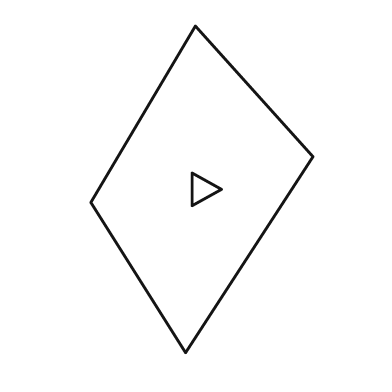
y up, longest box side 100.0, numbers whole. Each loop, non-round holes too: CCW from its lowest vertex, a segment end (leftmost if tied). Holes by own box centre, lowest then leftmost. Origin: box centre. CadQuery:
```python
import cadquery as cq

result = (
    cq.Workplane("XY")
    .moveTo(-5.0, -50.0)
    .lineTo(34.0, 10.0)
    .lineTo(-2.0, 50.0)
    .lineTo(-34.0, -4.0)
    .close()
    .moveTo(-3.0, -5.0)
    .lineTo(6.0, 0.0)
    .lineTo(-3.0, 5.0)
    .close()
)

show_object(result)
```